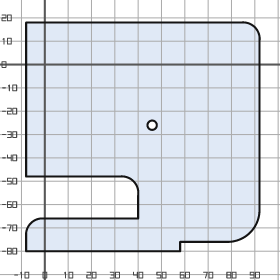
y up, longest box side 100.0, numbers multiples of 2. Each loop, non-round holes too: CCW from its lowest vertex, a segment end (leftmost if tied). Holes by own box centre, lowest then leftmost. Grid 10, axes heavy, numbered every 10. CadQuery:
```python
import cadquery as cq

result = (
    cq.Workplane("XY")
    .moveTo(-8.0, -80.0)
    .lineTo(58.0, -80.0)
    .lineTo(58.0, -76.0)
    .lineTo(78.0, -76.0)
    .threePointArc((88.0, -72.0), (92.0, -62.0))
    .lineTo(92.0, 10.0)
    .threePointArc((90.0, 16.0), (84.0, 18.0))
    .lineTo(-8.0, 18.0)
    .lineTo(-8.0, -48.0)
    .lineTo(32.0, -48.0)
    .threePointArc((38.0, -50.0), (40.0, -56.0))
    .lineTo(40.0, -66.0)
    .lineTo(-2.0, -66.0)
    .threePointArc((-6.0, -68.0), (-8.0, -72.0))
    .close()
    .moveTo(46.0, -26.0)
    .circle(2.0)
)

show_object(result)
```